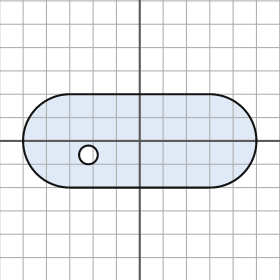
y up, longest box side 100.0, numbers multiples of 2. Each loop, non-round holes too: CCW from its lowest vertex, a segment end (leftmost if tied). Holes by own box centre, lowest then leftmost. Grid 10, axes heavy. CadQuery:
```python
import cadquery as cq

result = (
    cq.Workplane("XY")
    .moveTo(-30.0, -20.0)
    .lineTo(30.0, -20.0)
    .threePointArc((50.0, 0.0), (30.0, 20.0))
    .lineTo(-30.0, 20.0)
    .threePointArc((-50.0, 0.0), (-30.0, -20.0))
    .close()
    .moveTo(-22.0, -6.0)
    .circle(4.0)
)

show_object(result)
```